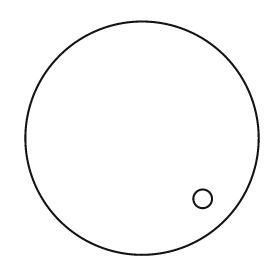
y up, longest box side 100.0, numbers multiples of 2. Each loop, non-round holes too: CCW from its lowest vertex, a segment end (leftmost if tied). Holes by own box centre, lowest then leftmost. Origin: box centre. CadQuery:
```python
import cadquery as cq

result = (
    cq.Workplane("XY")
    .moveTo(0.0, 0.0)
    .circle(50.0)
    .moveTo(26.0, -26.0)
    .circle(4.0)
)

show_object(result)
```